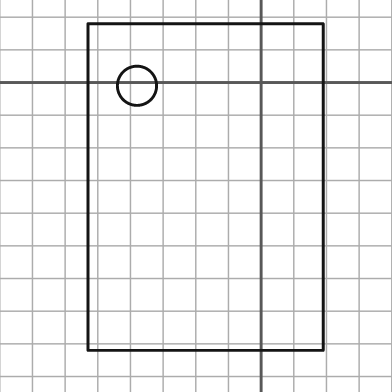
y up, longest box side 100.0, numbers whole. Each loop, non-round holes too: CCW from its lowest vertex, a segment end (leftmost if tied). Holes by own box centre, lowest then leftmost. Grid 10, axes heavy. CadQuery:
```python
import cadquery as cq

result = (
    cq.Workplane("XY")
    .moveTo(-53.0, -82.0)
    .lineTo(19.0, -82.0)
    .lineTo(19.0, 18.0)
    .lineTo(-53.0, 18.0)
    .close()
    .moveTo(-38.0, -1.0)
    .circle(6.0)
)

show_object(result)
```